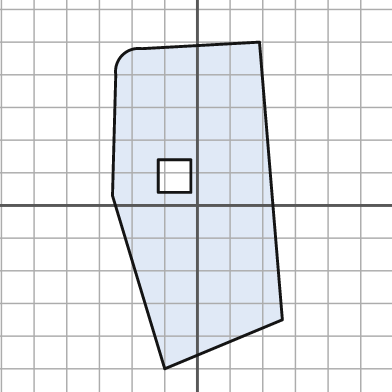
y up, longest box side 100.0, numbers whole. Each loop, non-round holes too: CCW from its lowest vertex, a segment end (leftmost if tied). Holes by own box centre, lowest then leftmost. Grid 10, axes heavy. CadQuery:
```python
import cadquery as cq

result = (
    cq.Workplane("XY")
    .moveTo(-10.0, -50.0)
    .lineTo(26.0, -35.0)
    .lineTo(19.0, 50.0)
    .lineTo(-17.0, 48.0)
    .threePointArc((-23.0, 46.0), (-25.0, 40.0))
    .lineTo(-26.0, 3.0)
    .close()
    .moveTo(-12.0, 4.0)
    .lineTo(-2.0, 4.0)
    .lineTo(-2.0, 14.0)
    .lineTo(-12.0, 14.0)
    .close()
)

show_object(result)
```